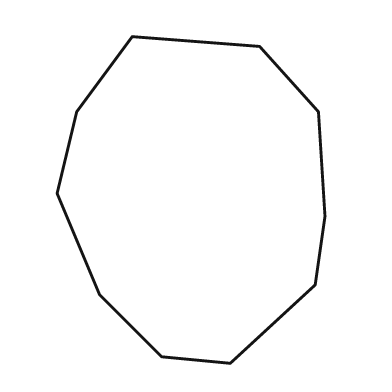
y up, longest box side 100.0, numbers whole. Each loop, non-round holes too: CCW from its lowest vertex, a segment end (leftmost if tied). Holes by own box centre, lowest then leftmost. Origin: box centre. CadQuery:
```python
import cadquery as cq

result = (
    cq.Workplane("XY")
    .moveTo(12.0, -50.0)
    .lineTo(38.0, -26.0)
    .lineTo(41.0, -5.0)
    .lineTo(39.0, 27.0)
    .lineTo(21.0, 47.0)
    .lineTo(-18.0, 50.0)
    .lineTo(-35.0, 27.0)
    .lineTo(-41.0, 2.0)
    .lineTo(-28.0, -29.0)
    .lineTo(-9.0, -48.0)
    .close()
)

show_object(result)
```